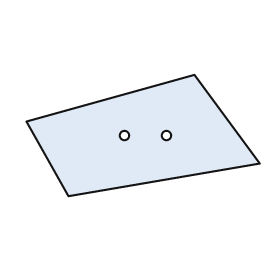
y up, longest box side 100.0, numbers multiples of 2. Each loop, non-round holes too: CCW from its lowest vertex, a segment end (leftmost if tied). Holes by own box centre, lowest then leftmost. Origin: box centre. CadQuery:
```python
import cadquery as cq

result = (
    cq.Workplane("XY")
    .moveTo(-32.0, -26.0)
    .lineTo(50.0, -12.0)
    .lineTo(22.0, 26.0)
    .lineTo(-50.0, 6.0)
    .close()
    .moveTo(-8.0, 0.0)
    .circle(2.0)
    .moveTo(10.0, 0.0)
    .circle(2.0)
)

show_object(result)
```